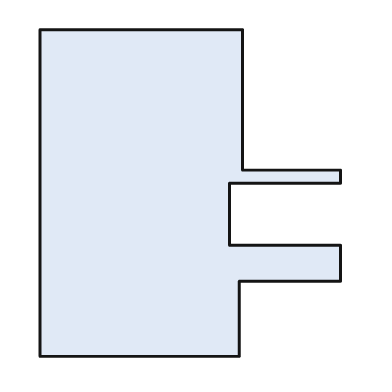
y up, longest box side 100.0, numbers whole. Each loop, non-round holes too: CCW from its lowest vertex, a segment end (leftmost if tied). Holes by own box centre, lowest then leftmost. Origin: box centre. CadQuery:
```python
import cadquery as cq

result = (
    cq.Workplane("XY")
    .moveTo(-46.0, -50.0)
    .lineTo(15.0, -50.0)
    .lineTo(15.0, -27.0)
    .lineTo(46.0, -27.0)
    .lineTo(46.0, -16.0)
    .lineTo(12.0, -16.0)
    .lineTo(12.0, 3.0)
    .lineTo(46.0, 3.0)
    .lineTo(46.0, 7.0)
    .lineTo(16.0, 7.0)
    .lineTo(16.0, 50.0)
    .lineTo(-46.0, 50.0)
    .close()
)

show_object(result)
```